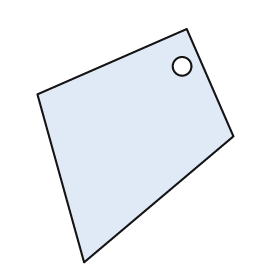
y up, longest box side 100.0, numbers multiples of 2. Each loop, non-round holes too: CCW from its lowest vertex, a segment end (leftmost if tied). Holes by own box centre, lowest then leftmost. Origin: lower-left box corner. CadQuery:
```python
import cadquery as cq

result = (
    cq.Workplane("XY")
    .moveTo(20.0, 0.0)
    .lineTo(84.0, 54.0)
    .lineTo(64.0, 100.0)
    .lineTo(0.0, 72.0)
    .close()
    .moveTo(62.0, 84.0)
    .circle(4.0)
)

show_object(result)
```